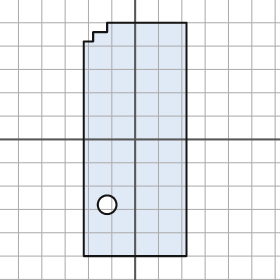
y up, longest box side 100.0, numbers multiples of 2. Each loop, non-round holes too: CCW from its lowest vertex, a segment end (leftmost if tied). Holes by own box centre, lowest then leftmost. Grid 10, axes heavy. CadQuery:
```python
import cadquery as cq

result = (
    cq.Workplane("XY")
    .moveTo(-22.0, -50.0)
    .lineTo(22.0, -50.0)
    .lineTo(22.0, 50.0)
    .lineTo(-12.0, 50.0)
    .lineTo(-12.0, 46.0)
    .lineTo(-18.0, 46.0)
    .lineTo(-18.0, 42.0)
    .lineTo(-22.0, 42.0)
    .close()
    .moveTo(-12.0, -28.0)
    .circle(4.0)
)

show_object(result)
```